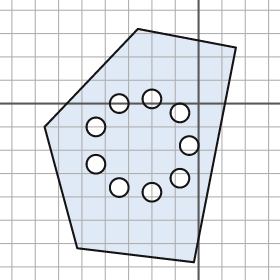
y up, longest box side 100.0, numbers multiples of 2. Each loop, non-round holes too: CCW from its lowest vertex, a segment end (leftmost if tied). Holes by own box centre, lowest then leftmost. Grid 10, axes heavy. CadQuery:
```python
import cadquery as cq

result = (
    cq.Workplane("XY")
    .moveTo(-2.0, -68.0)
    .lineTo(16.0, 24.0)
    .lineTo(-26.0, 32.0)
    .lineTo(-66.0, -10.0)
    .lineTo(-52.0, -62.0)
    .close()
    .moveTo(-20.0, -38.0)
    .circle(4.0)
    .moveTo(-34.0, -36.0)
    .circle(4.0)
    .moveTo(-8.0, -32.0)
    .circle(4.0)
    .moveTo(-44.0, -26.0)
    .circle(4.0)
    .moveTo(-4.0, -18.0)
    .circle(4.0)
    .moveTo(-44.0, -10.0)
    .circle(4.0)
    .moveTo(-8.0, -4.0)
    .circle(4.0)
    .moveTo(-34.0, 0.0)
    .circle(4.0)
    .moveTo(-20.0, 2.0)
    .circle(4.0)
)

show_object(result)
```